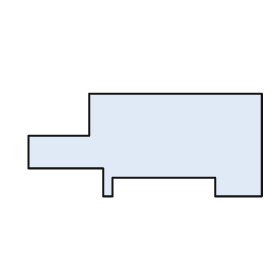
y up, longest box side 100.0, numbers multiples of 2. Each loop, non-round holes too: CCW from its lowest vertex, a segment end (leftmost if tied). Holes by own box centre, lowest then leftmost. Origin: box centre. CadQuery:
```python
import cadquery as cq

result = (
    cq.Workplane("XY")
    .moveTo(-18.0, -22.0)
    .lineTo(-14.0, -22.0)
    .lineTo(-14.0, -14.0)
    .lineTo(30.0, -14.0)
    .lineTo(30.0, -22.0)
    .lineTo(50.0, -22.0)
    .lineTo(50.0, 22.0)
    .lineTo(-24.0, 22.0)
    .lineTo(-24.0, 4.0)
    .lineTo(-50.0, 4.0)
    .lineTo(-50.0, -10.0)
    .lineTo(-18.0, -10.0)
    .close()
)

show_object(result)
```